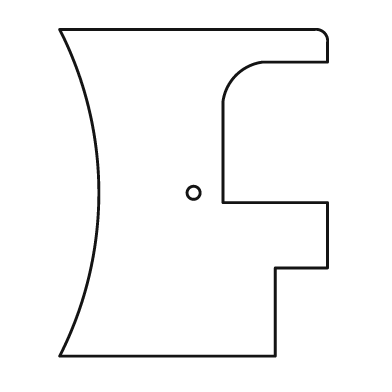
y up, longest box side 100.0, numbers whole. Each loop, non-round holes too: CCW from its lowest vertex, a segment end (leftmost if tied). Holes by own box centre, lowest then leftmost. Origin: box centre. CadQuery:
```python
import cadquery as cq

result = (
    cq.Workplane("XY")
    .moveTo(-41.0, -50.0)
    .lineTo(25.0, -50.0)
    .lineTo(25.0, -23.0)
    .lineTo(41.0, -23.0)
    .lineTo(41.0, -3.0)
    .lineTo(9.0, -3.0)
    .lineTo(9.0, 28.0)
    .threePointArc((13.0, 36.0), (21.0, 40.0))
    .lineTo(41.0, 40.0)
    .lineTo(41.0, 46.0)
    .threePointArc((40.0, 49.0), (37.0, 50.0))
    .lineTo(-41.0, 50.0)
    .threePointArc((-29.0, 0.0), (-41.0, -50.0))
    .close()
    .moveTo(0.0, 0.0)
    .circle(2.0)
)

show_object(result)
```